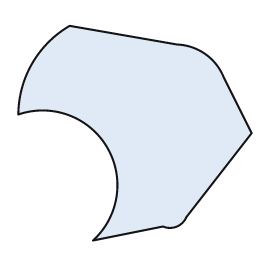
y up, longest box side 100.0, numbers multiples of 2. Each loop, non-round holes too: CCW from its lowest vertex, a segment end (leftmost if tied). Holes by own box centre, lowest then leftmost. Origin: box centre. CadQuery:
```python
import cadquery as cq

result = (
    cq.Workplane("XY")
    .moveTo(-18.0, -46.0)
    .lineTo(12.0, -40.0)
    .threePointArc((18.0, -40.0), (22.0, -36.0))
    .lineTo(50.0, 0.0)
    .lineTo(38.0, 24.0)
    .threePointArc((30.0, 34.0), (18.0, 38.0))
    .lineTo(-28.0, 46.0)
    .threePointArc((-44.0, 30.0), (-50.0, 8.0))
    .threePointArc((-12.0, -6.0), (-18.0, -46.0))
    .close()
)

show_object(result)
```